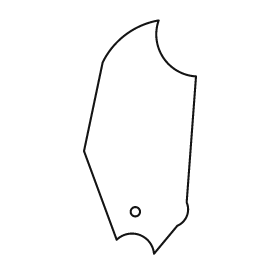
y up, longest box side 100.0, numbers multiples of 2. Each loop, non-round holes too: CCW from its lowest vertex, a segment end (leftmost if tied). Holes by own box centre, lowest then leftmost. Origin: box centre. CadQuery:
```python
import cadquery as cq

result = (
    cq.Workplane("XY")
    .moveTo(6.0, -50.0)
    .lineTo(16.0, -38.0)
    .threePointArc((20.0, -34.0), (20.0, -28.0))
    .lineTo(24.0, 26.0)
    .threePointArc((10.0, 34.0), (8.0, 50.0))
    .threePointArc((-6.0, 44.0), (-16.0, 32.0))
    .lineTo(-24.0, -6.0)
    .lineTo(-10.0, -44.0)
    .threePointArc((0.0, -42.0), (6.0, -50.0))
    .close()
    .moveTo(-2.0, -32.0)
    .circle(2.0)
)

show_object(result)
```